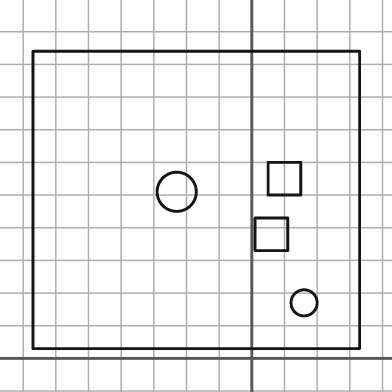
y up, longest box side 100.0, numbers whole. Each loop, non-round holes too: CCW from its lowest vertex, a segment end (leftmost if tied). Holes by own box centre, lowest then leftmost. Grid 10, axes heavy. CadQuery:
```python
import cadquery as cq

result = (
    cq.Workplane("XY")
    .moveTo(-67.0, 3.0)
    .lineTo(33.0, 3.0)
    .lineTo(33.0, 94.0)
    .lineTo(-67.0, 94.0)
    .close()
    .moveTo(16.0, 17.0)
    .circle(4.0)
    .moveTo(1.0, 33.0)
    .lineTo(11.0, 33.0)
    .lineTo(11.0, 43.0)
    .lineTo(1.0, 43.0)
    .close()
    .moveTo(-23.0, 51.0)
    .circle(6.0)
    .moveTo(5.0, 50.0)
    .lineTo(15.0, 50.0)
    .lineTo(15.0, 60.0)
    .lineTo(5.0, 60.0)
    .close()
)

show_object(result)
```